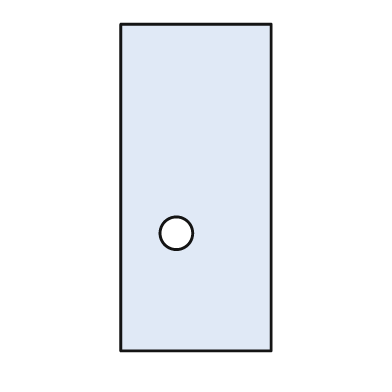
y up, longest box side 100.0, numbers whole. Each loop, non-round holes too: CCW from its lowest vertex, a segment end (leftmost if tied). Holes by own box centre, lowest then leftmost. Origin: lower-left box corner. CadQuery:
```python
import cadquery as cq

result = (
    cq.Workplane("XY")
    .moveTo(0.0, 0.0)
    .lineTo(46.0, 0.0)
    .lineTo(46.0, 100.0)
    .lineTo(0.0, 100.0)
    .close()
    .moveTo(17.0, 36.0)
    .circle(5.0)
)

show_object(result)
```